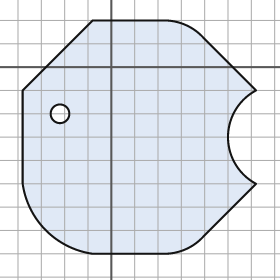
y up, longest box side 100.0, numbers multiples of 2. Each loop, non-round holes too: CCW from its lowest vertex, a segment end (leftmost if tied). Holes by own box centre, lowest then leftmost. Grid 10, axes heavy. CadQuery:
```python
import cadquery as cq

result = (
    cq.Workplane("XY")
    .moveTo(-8.0, -80.0)
    .lineTo(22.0, -80.0)
    .threePointArc((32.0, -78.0), (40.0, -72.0))
    .lineTo(62.0, -50.0)
    .threePointArc((50.0, -30.0), (62.0, -10.0))
    .lineTo(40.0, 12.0)
    .threePointArc((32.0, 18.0), (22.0, 20.0))
    .lineTo(-8.0, 20.0)
    .lineTo(-38.0, -10.0)
    .lineTo(-38.0, -50.0)
    .threePointArc((-28.0, -70.0), (-8.0, -80.0))
    .close()
    .moveTo(-22.0, -20.0)
    .circle(4.0)
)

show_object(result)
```